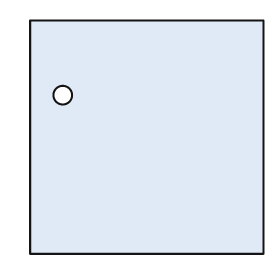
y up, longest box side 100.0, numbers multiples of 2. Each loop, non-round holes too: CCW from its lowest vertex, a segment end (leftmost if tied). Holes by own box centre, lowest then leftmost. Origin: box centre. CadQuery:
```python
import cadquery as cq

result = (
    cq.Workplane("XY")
    .moveTo(-50.0, -50.0)
    .lineTo(50.0, -50.0)
    .lineTo(50.0, 50.0)
    .lineTo(-50.0, 50.0)
    .close()
    .moveTo(-36.0, 18.0)
    .circle(4.0)
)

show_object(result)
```